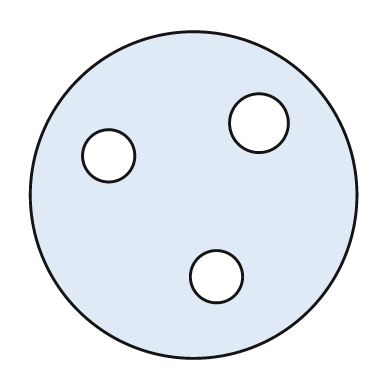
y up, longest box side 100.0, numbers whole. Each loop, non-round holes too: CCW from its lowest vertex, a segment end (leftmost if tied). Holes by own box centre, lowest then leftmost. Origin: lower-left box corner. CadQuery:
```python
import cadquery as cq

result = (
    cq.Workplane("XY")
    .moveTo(50.0, 50.0)
    .circle(50.0)
    .moveTo(57.0, 25.0)
    .circle(8.0)
    .moveTo(24.0, 62.0)
    .circle(8.0)
    .moveTo(70.0, 72.0)
    .circle(9.0)
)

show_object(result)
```